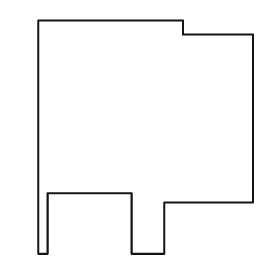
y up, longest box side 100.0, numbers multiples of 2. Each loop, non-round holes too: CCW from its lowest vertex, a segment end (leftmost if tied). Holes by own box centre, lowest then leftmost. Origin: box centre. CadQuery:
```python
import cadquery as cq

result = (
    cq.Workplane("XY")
    .moveTo(-46.0, -50.0)
    .lineTo(-42.0, -50.0)
    .lineTo(-42.0, -24.0)
    .lineTo(-6.0, -24.0)
    .lineTo(-6.0, -50.0)
    .lineTo(8.0, -50.0)
    .lineTo(8.0, -28.0)
    .lineTo(46.0, -28.0)
    .lineTo(46.0, 44.0)
    .lineTo(16.0, 44.0)
    .lineTo(16.0, 50.0)
    .lineTo(-46.0, 50.0)
    .close()
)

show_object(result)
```